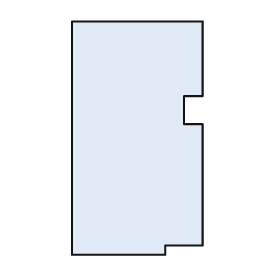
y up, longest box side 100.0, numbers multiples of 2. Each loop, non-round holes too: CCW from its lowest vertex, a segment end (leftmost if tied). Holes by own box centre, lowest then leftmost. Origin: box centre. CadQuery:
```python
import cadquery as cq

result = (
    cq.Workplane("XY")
    .moveTo(-28.0, -50.0)
    .lineTo(12.0, -50.0)
    .lineTo(12.0, -46.0)
    .lineTo(28.0, -46.0)
    .lineTo(28.0, 6.0)
    .lineTo(20.0, 6.0)
    .lineTo(20.0, 18.0)
    .lineTo(28.0, 18.0)
    .lineTo(28.0, 50.0)
    .lineTo(-28.0, 50.0)
    .close()
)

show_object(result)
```